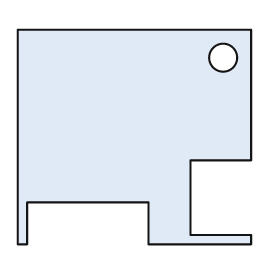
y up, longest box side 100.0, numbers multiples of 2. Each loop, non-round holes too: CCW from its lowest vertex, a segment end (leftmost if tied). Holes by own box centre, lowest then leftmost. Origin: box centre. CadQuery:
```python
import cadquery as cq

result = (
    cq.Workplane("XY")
    .moveTo(-50.0, -46.0)
    .lineTo(-46.0, -46.0)
    .lineTo(-46.0, -28.0)
    .lineTo(6.0, -28.0)
    .lineTo(6.0, -46.0)
    .lineTo(50.0, -46.0)
    .lineTo(50.0, -42.0)
    .lineTo(24.0, -42.0)
    .lineTo(24.0, -10.0)
    .lineTo(50.0, -10.0)
    .lineTo(50.0, 46.0)
    .lineTo(-50.0, 46.0)
    .close()
    .moveTo(38.0, 34.0)
    .circle(6.0)
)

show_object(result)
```